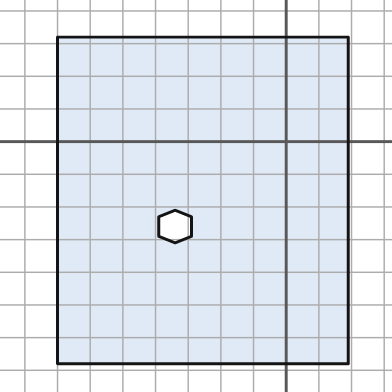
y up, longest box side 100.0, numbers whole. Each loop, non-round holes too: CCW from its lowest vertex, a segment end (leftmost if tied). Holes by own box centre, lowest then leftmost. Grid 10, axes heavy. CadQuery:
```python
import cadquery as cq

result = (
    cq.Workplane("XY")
    .moveTo(-70.0, -68.0)
    .lineTo(19.0, -68.0)
    .lineTo(19.0, 32.0)
    .lineTo(-70.0, 32.0)
    .close()
    .moveTo(-34.0, -31.0)
    .lineTo(-29.0, -29.0)
    .lineTo(-29.0, -23.0)
    .lineTo(-34.0, -21.0)
    .lineTo(-39.0, -23.0)
    .lineTo(-39.0, -29.0)
    .close()
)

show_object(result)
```